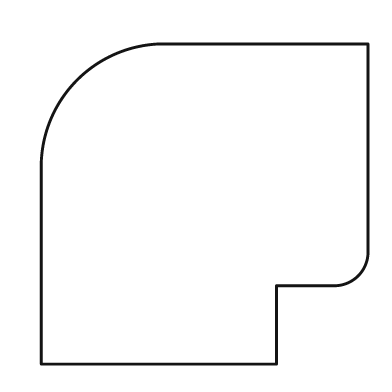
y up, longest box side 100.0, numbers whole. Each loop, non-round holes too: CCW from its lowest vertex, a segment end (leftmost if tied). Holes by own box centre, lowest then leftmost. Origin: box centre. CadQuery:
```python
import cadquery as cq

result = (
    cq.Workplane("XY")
    .moveTo(-50.0, -49.0)
    .lineTo(22.0, -49.0)
    .lineTo(22.0, -25.0)
    .lineTo(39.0, -25.0)
    .threePointArc((47.0, -22.0), (50.0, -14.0))
    .lineTo(50.0, 49.0)
    .lineTo(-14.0, 49.0)
    .threePointArc((-39.0, 38.0), (-50.0, 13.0))
    .close()
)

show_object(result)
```